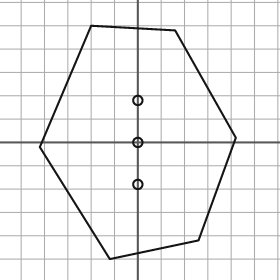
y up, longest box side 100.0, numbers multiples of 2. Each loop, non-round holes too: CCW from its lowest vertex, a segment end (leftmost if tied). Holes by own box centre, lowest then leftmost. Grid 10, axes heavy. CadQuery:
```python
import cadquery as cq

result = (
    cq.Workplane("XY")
    .moveTo(-12.0, -50.0)
    .lineTo(26.0, -42.0)
    .lineTo(42.0, 2.0)
    .lineTo(16.0, 48.0)
    .lineTo(-20.0, 50.0)
    .lineTo(-42.0, -2.0)
    .close()
    .moveTo(0.0, -18.0)
    .circle(2.0)
    .moveTo(0.0, 0.0)
    .circle(2.0)
    .moveTo(0.0, 18.0)
    .circle(2.0)
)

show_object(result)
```